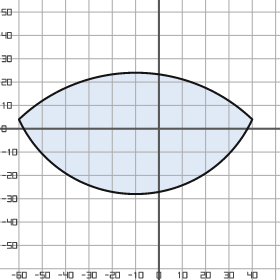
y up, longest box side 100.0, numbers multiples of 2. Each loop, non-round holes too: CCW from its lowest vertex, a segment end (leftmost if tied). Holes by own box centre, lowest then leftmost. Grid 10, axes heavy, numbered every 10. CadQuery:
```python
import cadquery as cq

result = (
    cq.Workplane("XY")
    .moveTo(-60.0, 4.0)
    .threePointArc((-10.0, -28.0), (40.0, 4.0))
    .threePointArc((-10.0, 24.0), (-60.0, 4.0))
    .close()
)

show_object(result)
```